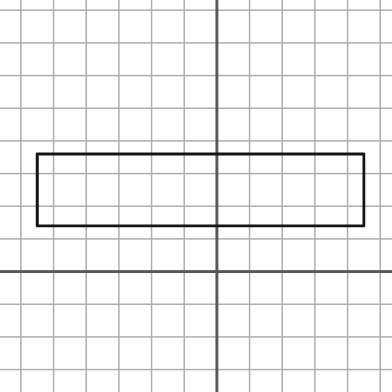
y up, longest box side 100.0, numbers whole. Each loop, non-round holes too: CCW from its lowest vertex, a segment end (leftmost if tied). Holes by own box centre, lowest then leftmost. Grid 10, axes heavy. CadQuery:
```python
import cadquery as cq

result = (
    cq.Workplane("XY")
    .moveTo(-55.0, 14.0)
    .lineTo(45.0, 14.0)
    .lineTo(45.0, 36.0)
    .lineTo(-55.0, 36.0)
    .close()
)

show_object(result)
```